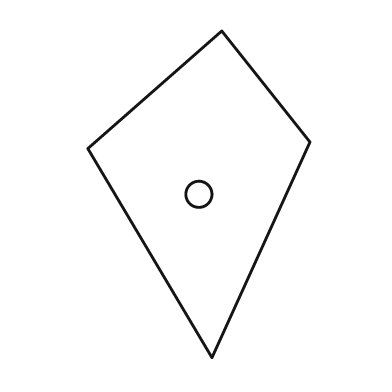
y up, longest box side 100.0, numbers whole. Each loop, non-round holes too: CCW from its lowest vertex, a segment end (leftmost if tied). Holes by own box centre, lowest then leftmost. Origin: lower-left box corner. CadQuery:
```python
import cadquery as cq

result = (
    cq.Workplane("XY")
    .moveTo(38.0, 0.0)
    .lineTo(68.0, 66.0)
    .lineTo(41.0, 100.0)
    .lineTo(0.0, 64.0)
    .close()
    .moveTo(34.0, 50.0)
    .circle(4.0)
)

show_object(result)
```